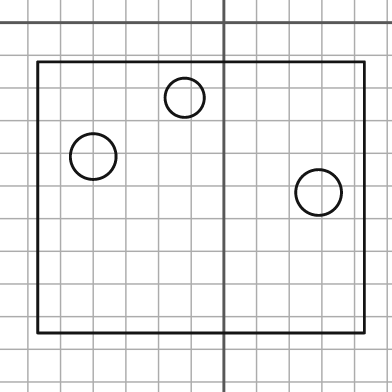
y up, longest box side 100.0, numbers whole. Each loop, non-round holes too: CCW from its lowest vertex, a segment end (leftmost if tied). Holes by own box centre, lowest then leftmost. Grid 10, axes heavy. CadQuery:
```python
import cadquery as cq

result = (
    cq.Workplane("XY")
    .moveTo(-57.0, -95.0)
    .lineTo(43.0, -95.0)
    .lineTo(43.0, -12.0)
    .lineTo(-57.0, -12.0)
    .close()
    .moveTo(29.0, -52.0)
    .circle(7.0)
    .moveTo(-40.0, -41.0)
    .circle(7.0)
    .moveTo(-12.0, -23.0)
    .circle(6.0)
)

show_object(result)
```